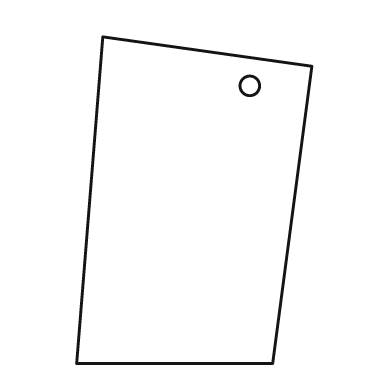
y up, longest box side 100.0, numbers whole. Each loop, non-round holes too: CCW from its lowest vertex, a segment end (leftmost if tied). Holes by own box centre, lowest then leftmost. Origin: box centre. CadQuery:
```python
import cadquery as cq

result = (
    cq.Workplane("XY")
    .moveTo(-36.0, -50.0)
    .lineTo(24.0, -50.0)
    .lineTo(36.0, 41.0)
    .lineTo(-28.0, 50.0)
    .close()
    .moveTo(17.0, 35.0)
    .circle(3.0)
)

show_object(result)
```